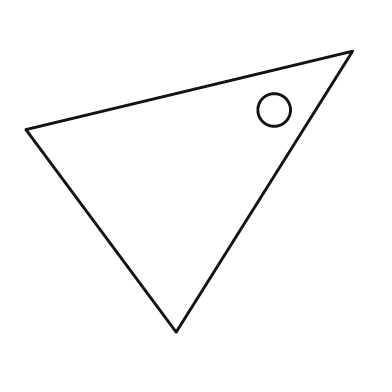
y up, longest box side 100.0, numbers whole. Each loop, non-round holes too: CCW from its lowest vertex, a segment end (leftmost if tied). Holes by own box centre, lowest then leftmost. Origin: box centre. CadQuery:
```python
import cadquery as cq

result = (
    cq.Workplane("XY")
    .moveTo(-4.0, -43.0)
    .lineTo(50.0, 43.0)
    .lineTo(-50.0, 19.0)
    .close()
    .moveTo(26.0, 25.0)
    .circle(5.0)
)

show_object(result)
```